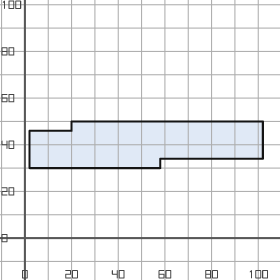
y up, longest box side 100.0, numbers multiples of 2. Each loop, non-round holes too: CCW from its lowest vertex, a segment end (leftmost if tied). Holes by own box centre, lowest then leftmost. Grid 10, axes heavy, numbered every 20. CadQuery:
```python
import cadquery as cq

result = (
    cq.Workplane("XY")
    .moveTo(2.0, 30.0)
    .lineTo(58.0, 30.0)
    .lineTo(58.0, 34.0)
    .lineTo(102.0, 34.0)
    .lineTo(102.0, 50.0)
    .lineTo(20.0, 50.0)
    .lineTo(20.0, 46.0)
    .lineTo(2.0, 46.0)
    .close()
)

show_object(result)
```